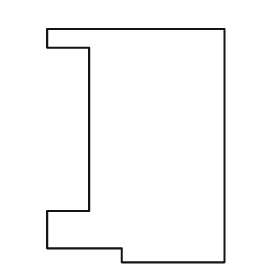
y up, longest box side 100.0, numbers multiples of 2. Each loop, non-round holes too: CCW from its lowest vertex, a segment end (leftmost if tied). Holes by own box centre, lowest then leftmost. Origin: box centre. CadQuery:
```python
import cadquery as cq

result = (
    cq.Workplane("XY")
    .moveTo(-6.0, -50.0)
    .lineTo(38.0, -50.0)
    .lineTo(38.0, 50.0)
    .lineTo(-38.0, 50.0)
    .lineTo(-38.0, 42.0)
    .lineTo(-20.0, 42.0)
    .lineTo(-20.0, -28.0)
    .lineTo(-38.0, -28.0)
    .lineTo(-38.0, -44.0)
    .lineTo(-6.0, -44.0)
    .close()
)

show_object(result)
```